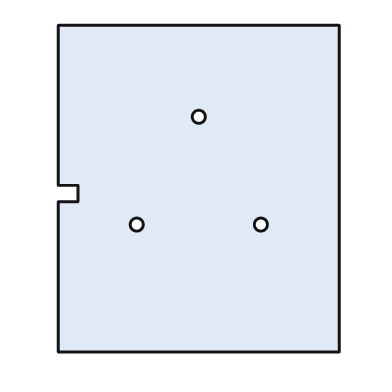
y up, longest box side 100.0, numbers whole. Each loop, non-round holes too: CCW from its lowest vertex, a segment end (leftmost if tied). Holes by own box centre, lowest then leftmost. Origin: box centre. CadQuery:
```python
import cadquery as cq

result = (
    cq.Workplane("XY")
    .moveTo(-43.0, -50.0)
    .lineTo(43.0, -50.0)
    .lineTo(43.0, 50.0)
    .lineTo(-43.0, 50.0)
    .lineTo(-43.0, 1.0)
    .lineTo(-37.0, 1.0)
    .lineTo(-37.0, -4.0)
    .lineTo(-43.0, -4.0)
    .close()
    .moveTo(-19.0, -11.0)
    .circle(2.0)
    .moveTo(19.0, -11.0)
    .circle(2.0)
    .moveTo(0.0, 22.0)
    .circle(2.0)
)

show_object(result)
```